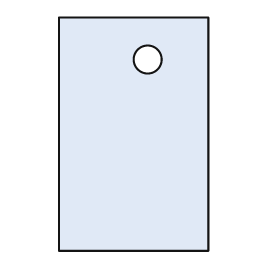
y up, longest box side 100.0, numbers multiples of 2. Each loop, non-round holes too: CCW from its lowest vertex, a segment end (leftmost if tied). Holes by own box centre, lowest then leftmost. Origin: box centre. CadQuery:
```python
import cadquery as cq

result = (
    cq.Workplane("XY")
    .moveTo(-32.0, -50.0)
    .lineTo(32.0, -50.0)
    .lineTo(32.0, 50.0)
    .lineTo(-32.0, 50.0)
    .close()
    .moveTo(6.0, 32.0)
    .circle(6.0)
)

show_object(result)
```